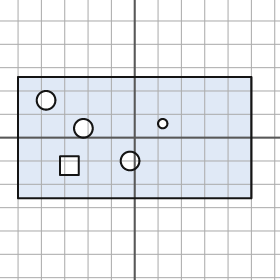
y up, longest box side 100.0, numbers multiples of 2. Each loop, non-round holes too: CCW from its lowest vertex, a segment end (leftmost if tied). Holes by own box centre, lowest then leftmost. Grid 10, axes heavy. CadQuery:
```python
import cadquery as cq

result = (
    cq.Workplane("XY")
    .moveTo(-50.0, -26.0)
    .lineTo(50.0, -26.0)
    .lineTo(50.0, 26.0)
    .lineTo(-50.0, 26.0)
    .close()
    .moveTo(-32.0, -16.0)
    .lineTo(-24.0, -16.0)
    .lineTo(-24.0, -8.0)
    .lineTo(-32.0, -8.0)
    .close()
    .moveTo(-2.0, -10.0)
    .circle(4.0)
    .moveTo(-22.0, 4.0)
    .circle(4.0)
    .moveTo(12.0, 6.0)
    .circle(2.0)
    .moveTo(-38.0, 16.0)
    .circle(4.0)
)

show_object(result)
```